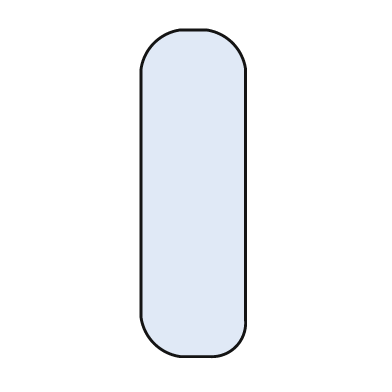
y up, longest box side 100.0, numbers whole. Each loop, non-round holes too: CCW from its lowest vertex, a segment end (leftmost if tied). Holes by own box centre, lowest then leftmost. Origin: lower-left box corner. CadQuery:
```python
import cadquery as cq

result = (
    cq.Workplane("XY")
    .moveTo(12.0, 0.0)
    .lineTo(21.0, 0.0)
    .threePointArc((29.0, 3.0), (32.0, 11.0))
    .lineTo(32.0, 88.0)
    .threePointArc((28.0, 96.0), (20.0, 100.0))
    .lineTo(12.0, 100.0)
    .threePointArc((4.0, 96.0), (0.0, 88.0))
    .lineTo(0.0, 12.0)
    .threePointArc((4.0, 4.0), (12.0, 0.0))
    .close()
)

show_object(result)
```